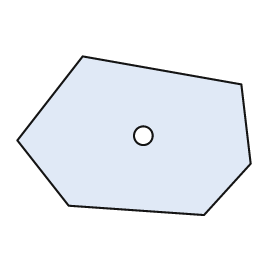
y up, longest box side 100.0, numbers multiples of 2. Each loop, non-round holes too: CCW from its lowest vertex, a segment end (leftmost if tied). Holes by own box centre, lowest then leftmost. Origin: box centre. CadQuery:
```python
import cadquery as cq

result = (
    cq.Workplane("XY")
    .moveTo(30.0, -34.0)
    .lineTo(50.0, -12.0)
    .lineTo(46.0, 22.0)
    .lineTo(-22.0, 34.0)
    .lineTo(-50.0, -2.0)
    .lineTo(-28.0, -30.0)
    .close()
    .moveTo(4.0, 0.0)
    .circle(4.0)
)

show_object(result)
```